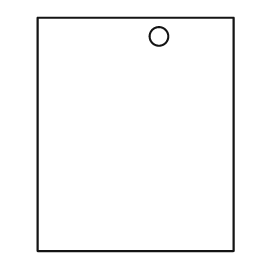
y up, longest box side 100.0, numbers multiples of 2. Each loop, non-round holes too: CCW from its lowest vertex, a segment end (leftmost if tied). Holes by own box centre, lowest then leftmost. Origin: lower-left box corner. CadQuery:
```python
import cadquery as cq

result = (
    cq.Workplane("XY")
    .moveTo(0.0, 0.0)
    .lineTo(84.0, 0.0)
    .lineTo(84.0, 100.0)
    .lineTo(0.0, 100.0)
    .close()
    .moveTo(52.0, 92.0)
    .circle(4.0)
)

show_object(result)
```